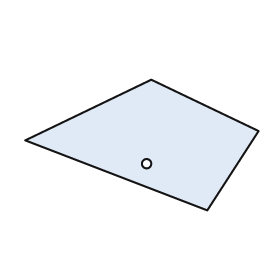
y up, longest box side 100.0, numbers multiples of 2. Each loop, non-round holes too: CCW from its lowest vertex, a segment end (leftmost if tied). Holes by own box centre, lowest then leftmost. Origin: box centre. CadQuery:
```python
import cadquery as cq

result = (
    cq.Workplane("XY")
    .moveTo(28.0, -28.0)
    .lineTo(50.0, 6.0)
    .lineTo(4.0, 28.0)
    .lineTo(-50.0, 2.0)
    .close()
    .moveTo(2.0, -8.0)
    .circle(2.0)
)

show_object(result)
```